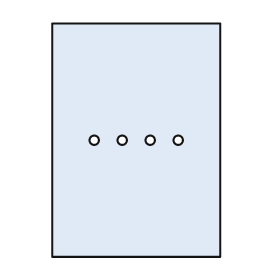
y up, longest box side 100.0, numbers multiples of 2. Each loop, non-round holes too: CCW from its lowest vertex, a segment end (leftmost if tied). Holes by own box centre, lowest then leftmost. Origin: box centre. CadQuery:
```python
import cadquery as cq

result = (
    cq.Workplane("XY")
    .moveTo(-36.0, -50.0)
    .lineTo(36.0, -50.0)
    .lineTo(36.0, 50.0)
    .lineTo(-36.0, 50.0)
    .close()
    .moveTo(-18.0, 0.0)
    .circle(2.0)
    .moveTo(-6.0, 0.0)
    .circle(2.0)
    .moveTo(6.0, 0.0)
    .circle(2.0)
    .moveTo(18.0, 0.0)
    .circle(2.0)
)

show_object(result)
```